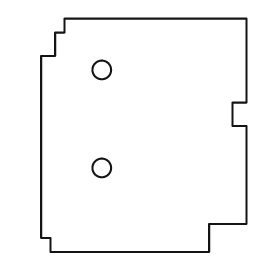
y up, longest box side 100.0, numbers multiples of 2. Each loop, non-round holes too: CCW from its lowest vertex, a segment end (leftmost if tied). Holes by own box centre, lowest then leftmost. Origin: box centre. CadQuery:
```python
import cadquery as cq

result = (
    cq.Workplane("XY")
    .moveTo(-40.0, -50.0)
    .lineTo(28.0, -50.0)
    .lineTo(28.0, -38.0)
    .lineTo(44.0, -38.0)
    .lineTo(44.0, 4.0)
    .lineTo(38.0, 4.0)
    .lineTo(38.0, 14.0)
    .lineTo(44.0, 14.0)
    .lineTo(44.0, 50.0)
    .lineTo(-34.0, 50.0)
    .lineTo(-34.0, 44.0)
    .lineTo(-38.0, 44.0)
    .lineTo(-38.0, 34.0)
    .lineTo(-44.0, 34.0)
    .lineTo(-44.0, -44.0)
    .lineTo(-40.0, -44.0)
    .close()
    .moveTo(-18.0, -14.0)
    .circle(4.0)
    .moveTo(-18.0, 28.0)
    .circle(4.0)
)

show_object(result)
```